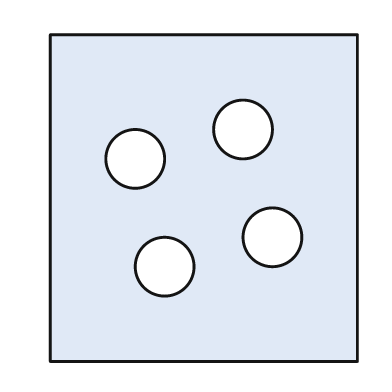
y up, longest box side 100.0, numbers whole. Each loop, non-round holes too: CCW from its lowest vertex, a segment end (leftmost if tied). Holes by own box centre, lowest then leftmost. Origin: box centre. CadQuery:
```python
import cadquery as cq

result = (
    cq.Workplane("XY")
    .moveTo(-47.0, -50.0)
    .lineTo(47.0, -50.0)
    .lineTo(47.0, 50.0)
    .lineTo(-47.0, 50.0)
    .close()
    .moveTo(-12.0, -21.0)
    .circle(9.0)
    .moveTo(21.0, -12.0)
    .circle(9.0)
    .moveTo(-21.0, 12.0)
    .circle(9.0)
    .moveTo(12.0, 21.0)
    .circle(9.0)
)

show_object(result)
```